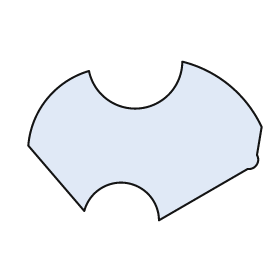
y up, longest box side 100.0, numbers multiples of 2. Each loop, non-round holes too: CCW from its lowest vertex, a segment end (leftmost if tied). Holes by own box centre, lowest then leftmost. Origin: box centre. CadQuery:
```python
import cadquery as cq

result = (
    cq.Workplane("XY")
    .moveTo(6.0, -34.0)
    .lineTo(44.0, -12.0)
    .threePointArc((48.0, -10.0), (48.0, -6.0))
    .lineTo(50.0, 6.0)
    .threePointArc((36.0, 24.0), (16.0, 34.0))
    .threePointArc((-2.0, 14.0), (-24.0, 30.0))
    .threePointArc((-42.0, 18.0), (-50.0, -2.0))
    .lineTo(-26.0, -30.0)
    .threePointArc((-8.0, -18.0), (6.0, -34.0))
    .close()
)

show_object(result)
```